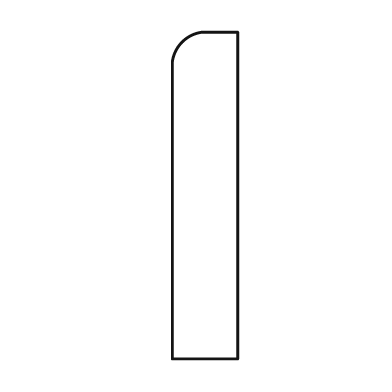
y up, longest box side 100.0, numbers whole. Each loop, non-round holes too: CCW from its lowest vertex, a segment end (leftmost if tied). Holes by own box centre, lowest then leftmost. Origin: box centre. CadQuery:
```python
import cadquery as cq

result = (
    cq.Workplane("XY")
    .moveTo(-10.0, -50.0)
    .lineTo(10.0, -50.0)
    .lineTo(10.0, 50.0)
    .lineTo(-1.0, 50.0)
    .threePointArc((-7.0, 47.0), (-10.0, 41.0))
    .close()
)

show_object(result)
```